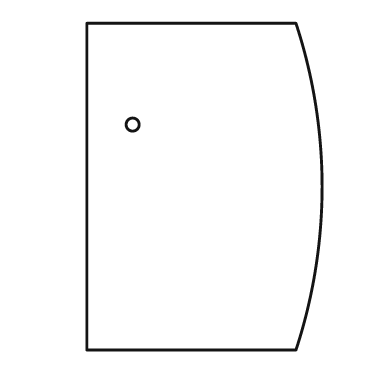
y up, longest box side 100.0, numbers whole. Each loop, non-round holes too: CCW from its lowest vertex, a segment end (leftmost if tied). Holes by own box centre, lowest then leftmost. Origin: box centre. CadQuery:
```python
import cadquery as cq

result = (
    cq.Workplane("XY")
    .moveTo(-36.0, -50.0)
    .lineTo(28.0, -50.0)
    .threePointArc((36.0, 0.0), (28.0, 50.0))
    .lineTo(-36.0, 50.0)
    .close()
    .moveTo(-22.0, 19.0)
    .circle(2.0)
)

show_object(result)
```